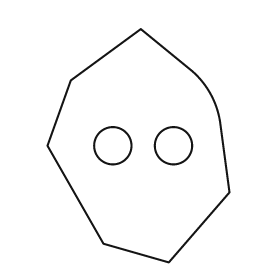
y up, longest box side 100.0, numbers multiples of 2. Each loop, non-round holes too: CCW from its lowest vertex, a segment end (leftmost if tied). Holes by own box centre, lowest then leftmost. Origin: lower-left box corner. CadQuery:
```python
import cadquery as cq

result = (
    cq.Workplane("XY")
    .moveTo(52.0, 0.0)
    .lineTo(78.0, 30.0)
    .lineTo(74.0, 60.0)
    .threePointArc((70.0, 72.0), (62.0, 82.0))
    .lineTo(40.0, 100.0)
    .lineTo(10.0, 78.0)
    .lineTo(0.0, 50.0)
    .lineTo(24.0, 8.0)
    .close()
    .moveTo(28.0, 50.0)
    .circle(8.0)
    .moveTo(54.0, 50.0)
    .circle(8.0)
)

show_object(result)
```